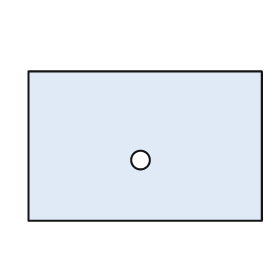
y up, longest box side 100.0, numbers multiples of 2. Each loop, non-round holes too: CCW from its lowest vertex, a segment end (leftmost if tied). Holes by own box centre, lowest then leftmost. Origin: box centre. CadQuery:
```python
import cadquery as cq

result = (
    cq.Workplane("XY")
    .moveTo(-50.0, -32.0)
    .lineTo(50.0, -32.0)
    .lineTo(50.0, 32.0)
    .lineTo(-50.0, 32.0)
    .close()
    .moveTo(-2.0, -6.0)
    .circle(4.0)
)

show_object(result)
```